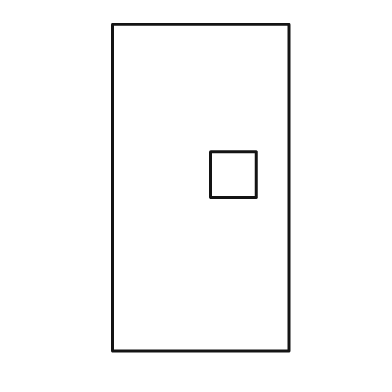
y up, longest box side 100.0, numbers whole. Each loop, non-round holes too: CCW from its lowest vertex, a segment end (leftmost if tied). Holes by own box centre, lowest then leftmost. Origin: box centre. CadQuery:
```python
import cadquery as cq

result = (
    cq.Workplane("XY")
    .moveTo(-27.0, -50.0)
    .lineTo(27.0, -50.0)
    .lineTo(27.0, 50.0)
    .lineTo(-27.0, 50.0)
    .close()
    .moveTo(3.0, -3.0)
    .lineTo(17.0, -3.0)
    .lineTo(17.0, 11.0)
    .lineTo(3.0, 11.0)
    .close()
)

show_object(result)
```